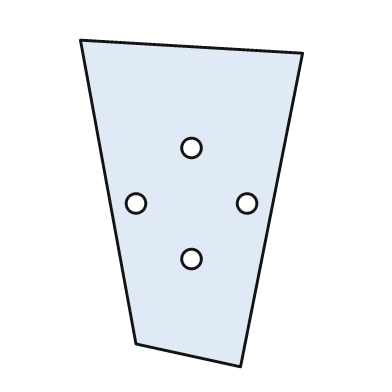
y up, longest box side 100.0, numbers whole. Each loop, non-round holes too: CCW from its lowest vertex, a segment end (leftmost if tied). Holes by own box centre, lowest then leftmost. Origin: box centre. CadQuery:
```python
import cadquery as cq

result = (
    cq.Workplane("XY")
    .moveTo(15.0, -50.0)
    .lineTo(34.0, 46.0)
    .lineTo(-34.0, 50.0)
    .lineTo(-17.0, -43.0)
    .close()
    .moveTo(0.0, -17.0)
    .circle(3.0)
    .moveTo(-17.0, 0.0)
    .circle(3.0)
    .moveTo(17.0, 0.0)
    .circle(3.0)
    .moveTo(0.0, 17.0)
    .circle(3.0)
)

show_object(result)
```